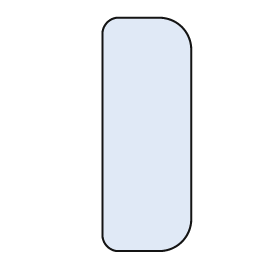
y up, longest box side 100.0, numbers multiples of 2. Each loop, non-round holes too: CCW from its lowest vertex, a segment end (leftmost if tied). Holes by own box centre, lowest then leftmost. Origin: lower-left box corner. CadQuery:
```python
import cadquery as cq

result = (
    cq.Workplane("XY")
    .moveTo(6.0, 0.0)
    .lineTo(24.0, 0.0)
    .threePointArc((34.0, 4.0), (38.0, 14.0))
    .lineTo(38.0, 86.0)
    .threePointArc((34.0, 96.0), (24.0, 100.0))
    .lineTo(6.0, 100.0)
    .threePointArc((2.0, 98.0), (0.0, 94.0))
    .lineTo(0.0, 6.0)
    .threePointArc((2.0, 2.0), (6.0, 0.0))
    .close()
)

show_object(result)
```